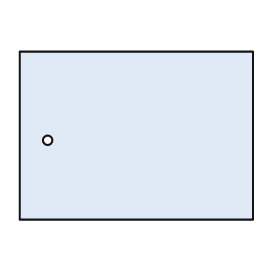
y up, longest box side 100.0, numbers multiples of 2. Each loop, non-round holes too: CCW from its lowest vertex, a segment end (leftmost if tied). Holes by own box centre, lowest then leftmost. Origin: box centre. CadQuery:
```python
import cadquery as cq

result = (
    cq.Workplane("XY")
    .moveTo(-50.0, -36.0)
    .lineTo(50.0, -36.0)
    .lineTo(50.0, 36.0)
    .lineTo(-50.0, 36.0)
    .close()
    .moveTo(-38.0, -2.0)
    .circle(2.0)
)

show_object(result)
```